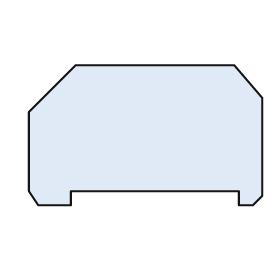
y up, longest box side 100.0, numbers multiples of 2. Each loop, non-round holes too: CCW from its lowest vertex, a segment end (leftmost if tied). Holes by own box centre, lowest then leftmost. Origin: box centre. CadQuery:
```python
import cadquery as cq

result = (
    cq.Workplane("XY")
    .moveTo(-46.0, -30.0)
    .lineTo(-32.0, -30.0)
    .lineTo(-32.0, -24.0)
    .lineTo(40.0, -24.0)
    .lineTo(40.0, -30.0)
    .lineTo(46.0, -30.0)
    .lineTo(50.0, -26.0)
    .lineTo(50.0, 16.0)
    .lineTo(38.0, 30.0)
    .lineTo(-30.0, 30.0)
    .lineTo(-50.0, 10.0)
    .lineTo(-50.0, -24.0)
    .close()
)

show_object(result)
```